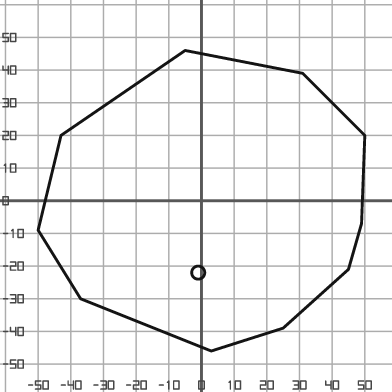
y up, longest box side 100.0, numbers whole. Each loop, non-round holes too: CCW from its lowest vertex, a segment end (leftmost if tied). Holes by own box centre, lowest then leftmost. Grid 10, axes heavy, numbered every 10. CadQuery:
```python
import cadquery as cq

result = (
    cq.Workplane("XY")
    .moveTo(3.0, -46.0)
    .lineTo(25.0, -39.0)
    .lineTo(45.0, -21.0)
    .lineTo(49.0, -7.0)
    .lineTo(50.0, 20.0)
    .lineTo(31.0, 39.0)
    .lineTo(-5.0, 46.0)
    .lineTo(-43.0, 20.0)
    .lineTo(-50.0, -9.0)
    .lineTo(-37.0, -30.0)
    .close()
    .moveTo(-1.0, -22.0)
    .circle(2.0)
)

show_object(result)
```